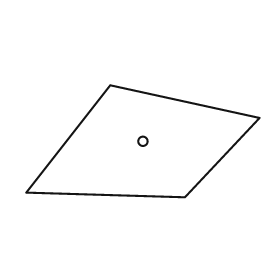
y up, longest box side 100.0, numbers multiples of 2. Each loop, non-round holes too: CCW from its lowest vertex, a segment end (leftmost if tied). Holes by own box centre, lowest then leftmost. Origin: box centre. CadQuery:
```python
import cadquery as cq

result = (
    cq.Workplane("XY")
    .moveTo(18.0, -24.0)
    .lineTo(50.0, 10.0)
    .lineTo(-14.0, 24.0)
    .lineTo(-50.0, -22.0)
    .close()
    .moveTo(0.0, 0.0)
    .circle(2.0)
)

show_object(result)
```